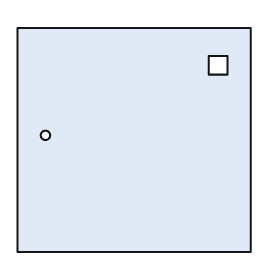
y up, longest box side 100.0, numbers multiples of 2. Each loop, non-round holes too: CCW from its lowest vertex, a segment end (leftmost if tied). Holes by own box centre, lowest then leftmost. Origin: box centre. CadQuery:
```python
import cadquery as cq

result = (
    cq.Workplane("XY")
    .moveTo(-50.0, -48.0)
    .lineTo(50.0, -48.0)
    .lineTo(50.0, 48.0)
    .lineTo(-50.0, 48.0)
    .close()
    .moveTo(-38.0, 2.0)
    .circle(2.0)
    .moveTo(32.0, 28.0)
    .lineTo(40.0, 28.0)
    .lineTo(40.0, 36.0)
    .lineTo(32.0, 36.0)
    .close()
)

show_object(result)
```